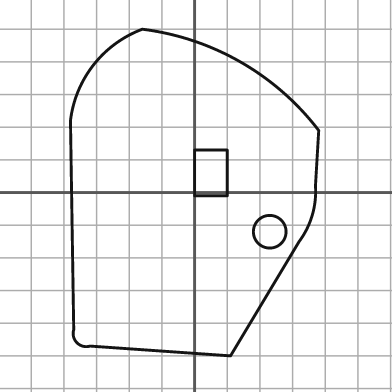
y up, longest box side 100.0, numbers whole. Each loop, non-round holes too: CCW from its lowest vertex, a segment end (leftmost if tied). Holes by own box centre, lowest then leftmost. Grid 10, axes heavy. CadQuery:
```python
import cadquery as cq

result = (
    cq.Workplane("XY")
    .moveTo(11.0, -50.0)
    .lineTo(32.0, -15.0)
    .threePointArc((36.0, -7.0), (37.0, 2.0))
    .lineTo(38.0, 19.0)
    .threePointArc((14.0, 40.0), (-16.0, 50.0))
    .threePointArc((-31.0, 39.0), (-38.0, 22.0))
    .lineTo(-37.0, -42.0)
    .threePointArc((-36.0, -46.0), (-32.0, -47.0))
    .close()
    .moveTo(23.0, -12.0)
    .circle(5.0)
    .moveTo(0.0, -1.0)
    .lineTo(10.0, -1.0)
    .lineTo(10.0, 13.0)
    .lineTo(0.0, 13.0)
    .close()
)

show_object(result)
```